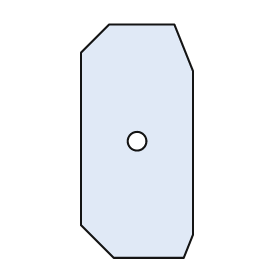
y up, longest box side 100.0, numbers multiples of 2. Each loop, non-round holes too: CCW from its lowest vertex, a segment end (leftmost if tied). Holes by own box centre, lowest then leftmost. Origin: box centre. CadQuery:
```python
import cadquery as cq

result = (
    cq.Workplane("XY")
    .moveTo(-10.0, -50.0)
    .lineTo(20.0, -50.0)
    .lineTo(24.0, -40.0)
    .lineTo(24.0, 30.0)
    .lineTo(16.0, 50.0)
    .lineTo(-12.0, 50.0)
    .lineTo(-24.0, 38.0)
    .lineTo(-24.0, -36.0)
    .close()
    .moveTo(0.0, 0.0)
    .circle(4.0)
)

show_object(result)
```